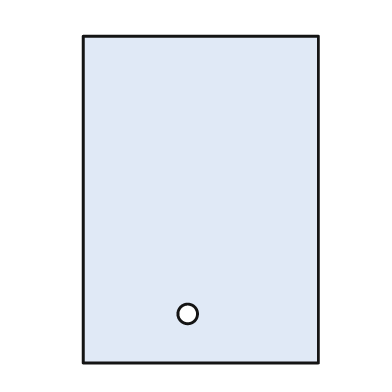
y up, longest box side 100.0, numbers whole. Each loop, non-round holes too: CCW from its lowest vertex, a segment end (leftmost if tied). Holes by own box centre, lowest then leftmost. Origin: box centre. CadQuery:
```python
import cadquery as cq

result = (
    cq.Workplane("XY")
    .moveTo(-36.0, -50.0)
    .lineTo(36.0, -50.0)
    .lineTo(36.0, 50.0)
    .lineTo(-36.0, 50.0)
    .close()
    .moveTo(-4.0, -35.0)
    .circle(3.0)
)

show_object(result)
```